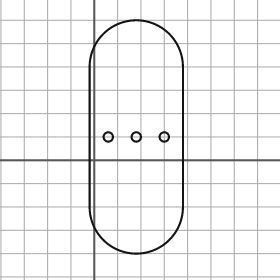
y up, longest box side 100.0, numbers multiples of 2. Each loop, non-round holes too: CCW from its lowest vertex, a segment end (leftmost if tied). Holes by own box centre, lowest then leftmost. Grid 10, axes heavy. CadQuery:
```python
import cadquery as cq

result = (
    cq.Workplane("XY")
    .moveTo(-2.0, -20.0)
    .threePointArc((18.0, -40.0), (38.0, -20.0))
    .lineTo(38.0, 40.0)
    .threePointArc((18.0, 60.0), (-2.0, 40.0))
    .close()
    .moveTo(6.0, 10.0)
    .circle(2.0)
    .moveTo(18.0, 10.0)
    .circle(2.0)
    .moveTo(30.0, 10.0)
    .circle(2.0)
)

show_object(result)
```